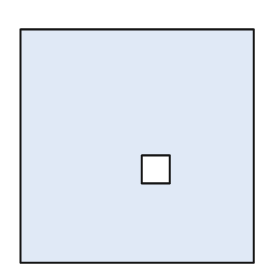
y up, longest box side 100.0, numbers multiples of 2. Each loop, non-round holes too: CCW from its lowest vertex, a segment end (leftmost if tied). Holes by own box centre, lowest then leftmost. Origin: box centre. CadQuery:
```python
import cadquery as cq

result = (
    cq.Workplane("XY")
    .moveTo(-50.0, -50.0)
    .lineTo(50.0, -50.0)
    .lineTo(50.0, 50.0)
    .lineTo(-50.0, 50.0)
    .close()
    .moveTo(2.0, -16.0)
    .lineTo(14.0, -16.0)
    .lineTo(14.0, -4.0)
    .lineTo(2.0, -4.0)
    .close()
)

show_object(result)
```